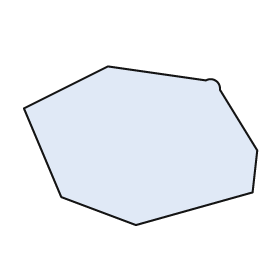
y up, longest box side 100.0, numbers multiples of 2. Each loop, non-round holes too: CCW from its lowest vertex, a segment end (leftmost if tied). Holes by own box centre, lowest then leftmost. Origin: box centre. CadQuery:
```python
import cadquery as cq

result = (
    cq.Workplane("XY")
    .moveTo(-2.0, -34.0)
    .lineTo(48.0, -20.0)
    .lineTo(50.0, -2.0)
    .lineTo(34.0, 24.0)
    .threePointArc((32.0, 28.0), (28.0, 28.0))
    .lineTo(-14.0, 34.0)
    .lineTo(-50.0, 16.0)
    .lineTo(-34.0, -22.0)
    .close()
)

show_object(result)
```